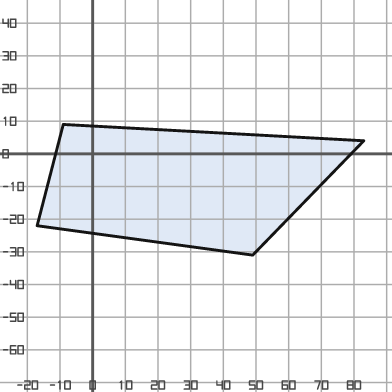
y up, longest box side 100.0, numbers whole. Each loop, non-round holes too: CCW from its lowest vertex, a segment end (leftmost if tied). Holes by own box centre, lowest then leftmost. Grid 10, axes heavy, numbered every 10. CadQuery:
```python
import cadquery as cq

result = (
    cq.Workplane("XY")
    .moveTo(49.0, -31.0)
    .lineTo(83.0, 4.0)
    .lineTo(-9.0, 9.0)
    .lineTo(-17.0, -22.0)
    .close()
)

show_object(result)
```